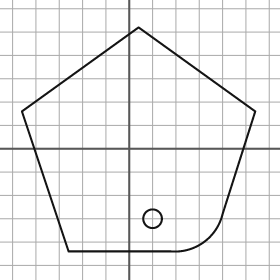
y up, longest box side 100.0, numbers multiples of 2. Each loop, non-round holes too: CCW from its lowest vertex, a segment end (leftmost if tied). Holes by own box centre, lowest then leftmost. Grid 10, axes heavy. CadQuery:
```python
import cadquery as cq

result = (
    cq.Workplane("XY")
    .moveTo(-26.0, -44.0)
    .lineTo(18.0, -44.0)
    .threePointArc((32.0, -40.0), (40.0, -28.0))
    .lineTo(54.0, 16.0)
    .lineTo(4.0, 52.0)
    .lineTo(-46.0, 16.0)
    .close()
    .moveTo(10.0, -30.0)
    .circle(4.0)
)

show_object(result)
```